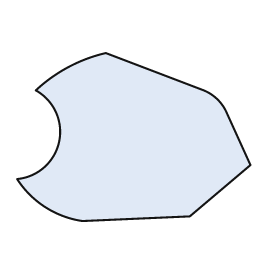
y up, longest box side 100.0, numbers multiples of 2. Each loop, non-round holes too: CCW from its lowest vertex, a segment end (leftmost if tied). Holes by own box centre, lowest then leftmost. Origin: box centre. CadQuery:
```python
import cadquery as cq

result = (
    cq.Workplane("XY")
    .moveTo(-22.0, -36.0)
    .lineTo(24.0, -34.0)
    .lineTo(50.0, -12.0)
    .lineTo(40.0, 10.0)
    .threePointArc((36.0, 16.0), (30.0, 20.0))
    .lineTo(-12.0, 36.0)
    .threePointArc((-28.0, 30.0), (-42.0, 20.0))
    .threePointArc((-32.0, -2.0), (-50.0, -18.0))
    .threePointArc((-38.0, -30.0), (-22.0, -36.0))
    .close()
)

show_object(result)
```